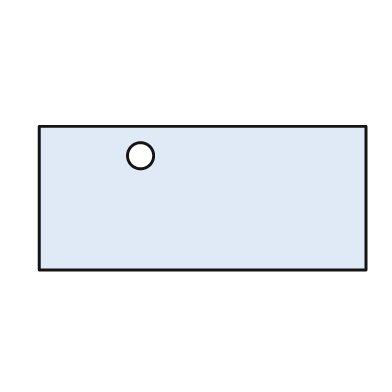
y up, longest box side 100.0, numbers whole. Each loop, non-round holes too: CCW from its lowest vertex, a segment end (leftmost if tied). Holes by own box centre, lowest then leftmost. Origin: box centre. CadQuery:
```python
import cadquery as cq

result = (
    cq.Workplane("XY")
    .moveTo(-50.0, -22.0)
    .lineTo(50.0, -22.0)
    .lineTo(50.0, 22.0)
    .lineTo(-50.0, 22.0)
    .close()
    .moveTo(-19.0, 13.0)
    .circle(4.0)
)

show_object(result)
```